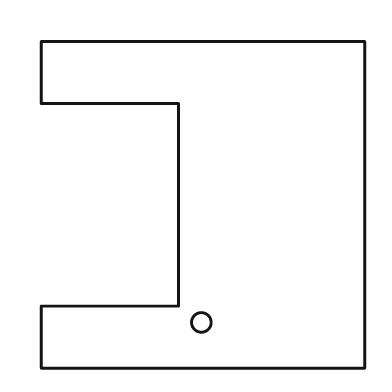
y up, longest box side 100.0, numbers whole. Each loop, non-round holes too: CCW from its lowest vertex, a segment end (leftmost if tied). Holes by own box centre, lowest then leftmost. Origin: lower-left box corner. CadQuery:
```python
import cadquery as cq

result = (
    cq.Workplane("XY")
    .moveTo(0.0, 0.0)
    .lineTo(99.0, 0.0)
    .lineTo(99.0, 100.0)
    .lineTo(0.0, 100.0)
    .lineTo(0.0, 81.0)
    .lineTo(42.0, 81.0)
    .lineTo(42.0, 19.0)
    .lineTo(0.0, 19.0)
    .close()
    .moveTo(49.0, 14.0)
    .circle(3.0)
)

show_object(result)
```